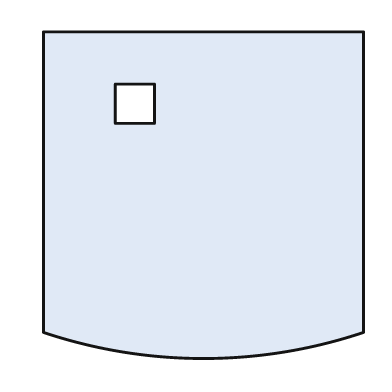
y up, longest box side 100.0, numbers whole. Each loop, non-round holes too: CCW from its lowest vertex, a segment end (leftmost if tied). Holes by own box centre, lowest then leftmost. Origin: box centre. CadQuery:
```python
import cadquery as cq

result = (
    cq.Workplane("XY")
    .moveTo(-49.0, -42.0)
    .threePointArc((0.0, -50.0), (49.0, -42.0))
    .lineTo(49.0, 50.0)
    .lineTo(-49.0, 50.0)
    .close()
    .moveTo(-27.0, 22.0)
    .lineTo(-15.0, 22.0)
    .lineTo(-15.0, 34.0)
    .lineTo(-27.0, 34.0)
    .close()
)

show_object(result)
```